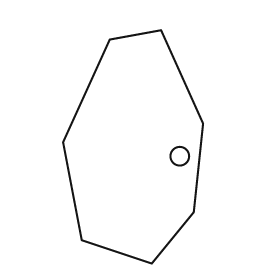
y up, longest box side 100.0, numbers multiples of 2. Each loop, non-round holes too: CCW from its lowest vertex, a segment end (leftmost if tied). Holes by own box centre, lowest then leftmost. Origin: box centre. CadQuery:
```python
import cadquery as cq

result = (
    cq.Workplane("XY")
    .moveTo(8.0, -50.0)
    .lineTo(26.0, -28.0)
    .lineTo(30.0, 10.0)
    .lineTo(12.0, 50.0)
    .lineTo(-10.0, 46.0)
    .lineTo(-30.0, 2.0)
    .lineTo(-22.0, -40.0)
    .close()
    .moveTo(20.0, -4.0)
    .circle(4.0)
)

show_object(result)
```